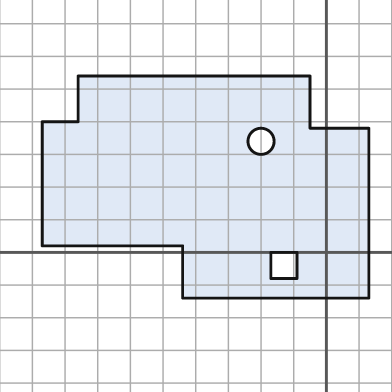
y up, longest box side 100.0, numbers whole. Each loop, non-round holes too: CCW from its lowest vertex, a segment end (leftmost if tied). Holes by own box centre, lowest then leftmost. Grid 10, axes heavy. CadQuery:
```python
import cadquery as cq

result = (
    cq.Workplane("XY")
    .moveTo(-44.0, -14.0)
    .lineTo(13.0, -14.0)
    .lineTo(13.0, 38.0)
    .lineTo(-5.0, 38.0)
    .lineTo(-5.0, 54.0)
    .lineTo(-76.0, 54.0)
    .lineTo(-76.0, 40.0)
    .lineTo(-87.0, 40.0)
    .lineTo(-87.0, 2.0)
    .lineTo(-44.0, 2.0)
    .close()
    .moveTo(-17.0, -8.0)
    .lineTo(-9.0, -8.0)
    .lineTo(-9.0, 0.0)
    .lineTo(-17.0, 0.0)
    .close()
    .moveTo(-20.0, 34.0)
    .circle(4.0)
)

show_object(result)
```